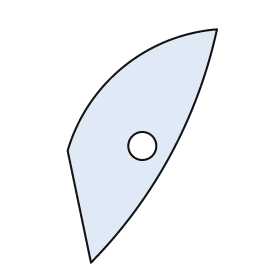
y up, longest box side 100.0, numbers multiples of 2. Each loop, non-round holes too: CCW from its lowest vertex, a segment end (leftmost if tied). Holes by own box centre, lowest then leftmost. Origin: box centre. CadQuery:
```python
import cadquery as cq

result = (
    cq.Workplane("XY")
    .moveTo(-22.0, -50.0)
    .threePointArc((12.0, -4.0), (32.0, 50.0))
    .threePointArc((-8.0, 34.0), (-32.0, -2.0))
    .close()
    .moveTo(0.0, 0.0)
    .circle(6.0)
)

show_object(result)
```